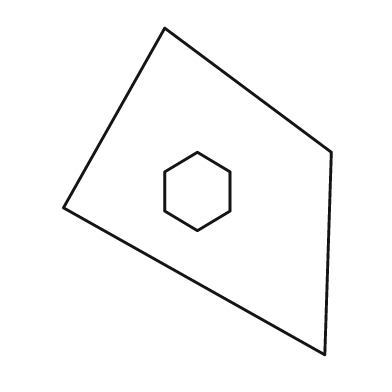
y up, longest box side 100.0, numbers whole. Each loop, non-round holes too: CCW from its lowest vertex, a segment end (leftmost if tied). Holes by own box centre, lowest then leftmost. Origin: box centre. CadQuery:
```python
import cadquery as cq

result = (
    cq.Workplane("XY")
    .moveTo(39.0, -50.0)
    .lineTo(41.0, 12.0)
    .lineTo(-10.0, 50.0)
    .lineTo(-41.0, -5.0)
    .close()
    .moveTo(0.0, -12.0)
    .lineTo(10.0, -6.0)
    .lineTo(10.0, 6.0)
    .lineTo(0.0, 12.0)
    .lineTo(-10.0, 6.0)
    .lineTo(-10.0, -6.0)
    .close()
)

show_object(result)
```